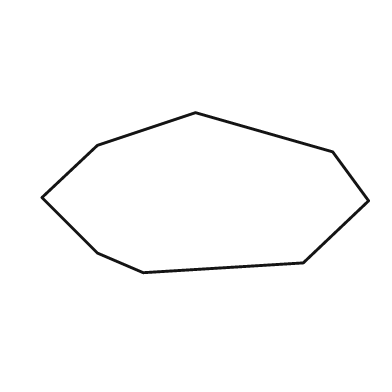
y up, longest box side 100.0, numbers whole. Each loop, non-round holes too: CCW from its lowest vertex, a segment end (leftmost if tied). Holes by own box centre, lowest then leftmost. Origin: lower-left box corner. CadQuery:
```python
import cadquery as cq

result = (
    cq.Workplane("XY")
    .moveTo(31.0, 0.0)
    .lineTo(80.0, 3.0)
    .lineTo(100.0, 22.0)
    .lineTo(89.0, 37.0)
    .lineTo(47.0, 49.0)
    .lineTo(17.0, 39.0)
    .lineTo(0.0, 23.0)
    .lineTo(17.0, 6.0)
    .close()
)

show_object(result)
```